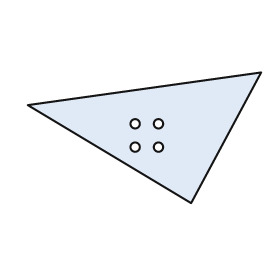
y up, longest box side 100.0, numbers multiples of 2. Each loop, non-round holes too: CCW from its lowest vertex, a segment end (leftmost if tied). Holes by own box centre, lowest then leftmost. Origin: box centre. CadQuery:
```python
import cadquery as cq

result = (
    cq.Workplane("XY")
    .moveTo(20.0, -28.0)
    .lineTo(50.0, 28.0)
    .lineTo(-50.0, 14.0)
    .close()
    .moveTo(-4.0, -4.0)
    .circle(2.0)
    .moveTo(6.0, -4.0)
    .circle(2.0)
    .moveTo(-4.0, 6.0)
    .circle(2.0)
    .moveTo(6.0, 6.0)
    .circle(2.0)
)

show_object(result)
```